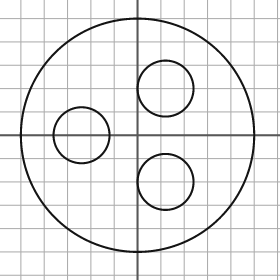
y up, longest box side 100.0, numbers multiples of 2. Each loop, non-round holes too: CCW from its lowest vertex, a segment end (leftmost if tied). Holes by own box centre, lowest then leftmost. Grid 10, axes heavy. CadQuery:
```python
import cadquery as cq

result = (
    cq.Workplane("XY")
    .moveTo(0.0, 0.0)
    .circle(50.0)
    .moveTo(12.0, -20.0)
    .circle(12.0)
    .moveTo(-24.0, 0.0)
    .circle(12.0)
    .moveTo(12.0, 20.0)
    .circle(12.0)
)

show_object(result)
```